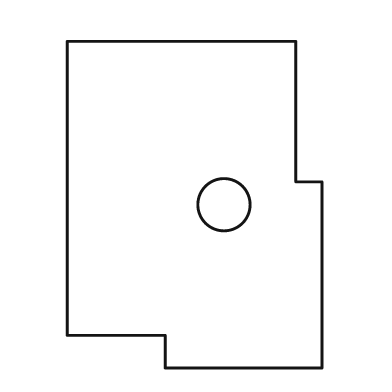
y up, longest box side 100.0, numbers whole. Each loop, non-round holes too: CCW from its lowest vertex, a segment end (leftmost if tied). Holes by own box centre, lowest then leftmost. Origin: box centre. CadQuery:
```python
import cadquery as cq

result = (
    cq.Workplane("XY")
    .moveTo(-9.0, -50.0)
    .lineTo(39.0, -50.0)
    .lineTo(39.0, 7.0)
    .lineTo(31.0, 7.0)
    .lineTo(31.0, 50.0)
    .lineTo(-39.0, 50.0)
    .lineTo(-39.0, -40.0)
    .lineTo(-9.0, -40.0)
    .close()
    .moveTo(9.0, 0.0)
    .circle(8.0)
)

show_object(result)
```